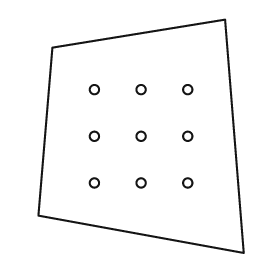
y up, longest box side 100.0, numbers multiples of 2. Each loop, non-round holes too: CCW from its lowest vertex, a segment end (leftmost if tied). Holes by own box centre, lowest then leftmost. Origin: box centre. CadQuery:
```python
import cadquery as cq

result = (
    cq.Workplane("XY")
    .moveTo(44.0, -50.0)
    .lineTo(36.0, 50.0)
    .lineTo(-38.0, 38.0)
    .lineTo(-44.0, -34.0)
    .close()
    .moveTo(-20.0, -20.0)
    .circle(2.0)
    .moveTo(0.0, -20.0)
    .circle(2.0)
    .moveTo(20.0, -20.0)
    .circle(2.0)
    .moveTo(-20.0, 0.0)
    .circle(2.0)
    .moveTo(0.0, 0.0)
    .circle(2.0)
    .moveTo(20.0, 0.0)
    .circle(2.0)
    .moveTo(-20.0, 20.0)
    .circle(2.0)
    .moveTo(0.0, 20.0)
    .circle(2.0)
    .moveTo(20.0, 20.0)
    .circle(2.0)
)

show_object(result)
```